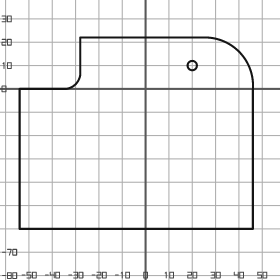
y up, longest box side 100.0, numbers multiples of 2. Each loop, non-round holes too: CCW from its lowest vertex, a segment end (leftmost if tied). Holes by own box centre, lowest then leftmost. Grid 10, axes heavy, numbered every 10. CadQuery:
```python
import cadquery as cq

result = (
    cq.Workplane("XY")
    .moveTo(-54.0, -60.0)
    .lineTo(46.0, -60.0)
    .lineTo(46.0, 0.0)
    .threePointArc((40.0, 16.0), (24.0, 22.0))
    .lineTo(-28.0, 22.0)
    .lineTo(-28.0, 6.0)
    .threePointArc((-30.0, 2.0), (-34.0, 0.0))
    .lineTo(-54.0, 0.0)
    .close()
    .moveTo(20.0, 10.0)
    .circle(2.0)
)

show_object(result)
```